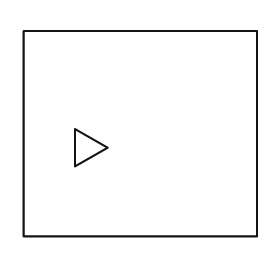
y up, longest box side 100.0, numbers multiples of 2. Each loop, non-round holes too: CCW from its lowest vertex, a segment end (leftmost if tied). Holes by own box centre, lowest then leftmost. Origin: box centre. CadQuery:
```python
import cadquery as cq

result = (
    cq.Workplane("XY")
    .moveTo(-50.0, -44.0)
    .lineTo(50.0, -44.0)
    .lineTo(50.0, 44.0)
    .lineTo(-50.0, 44.0)
    .close()
    .moveTo(-28.0, -14.0)
    .lineTo(-14.0, -6.0)
    .lineTo(-28.0, 2.0)
    .close()
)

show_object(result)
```